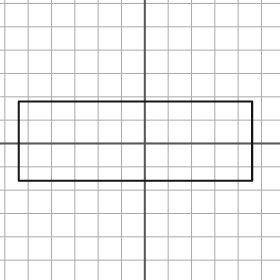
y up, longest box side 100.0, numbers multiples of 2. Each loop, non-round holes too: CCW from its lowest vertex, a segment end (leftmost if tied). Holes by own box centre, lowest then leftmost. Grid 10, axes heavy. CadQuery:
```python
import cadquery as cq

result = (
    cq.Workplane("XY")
    .moveTo(-54.0, -16.0)
    .lineTo(46.0, -16.0)
    .lineTo(46.0, 18.0)
    .lineTo(-54.0, 18.0)
    .close()
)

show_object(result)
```